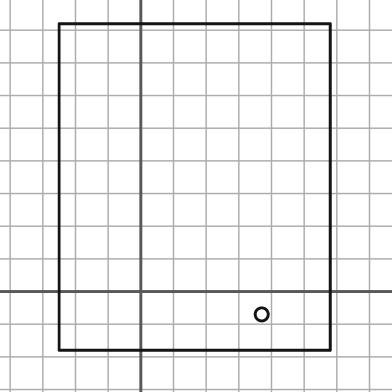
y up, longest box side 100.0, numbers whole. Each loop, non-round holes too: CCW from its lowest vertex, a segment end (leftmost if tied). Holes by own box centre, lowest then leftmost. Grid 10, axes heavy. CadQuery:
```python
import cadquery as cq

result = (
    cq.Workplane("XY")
    .moveTo(-25.0, -18.0)
    .lineTo(58.0, -18.0)
    .lineTo(58.0, 82.0)
    .lineTo(-25.0, 82.0)
    .close()
    .moveTo(37.0, -7.0)
    .circle(2.0)
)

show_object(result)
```